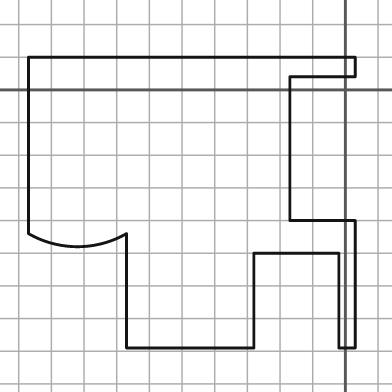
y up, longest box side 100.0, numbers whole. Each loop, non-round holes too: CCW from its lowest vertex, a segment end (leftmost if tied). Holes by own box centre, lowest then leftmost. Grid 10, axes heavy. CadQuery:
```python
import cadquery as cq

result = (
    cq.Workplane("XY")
    .moveTo(-67.0, -79.0)
    .lineTo(-28.0, -79.0)
    .lineTo(-28.0, -50.0)
    .lineTo(-2.0, -50.0)
    .lineTo(-2.0, -79.0)
    .lineTo(3.0, -79.0)
    .lineTo(3.0, -40.0)
    .lineTo(-17.0, -40.0)
    .lineTo(-17.0, 4.0)
    .lineTo(3.0, 4.0)
    .lineTo(3.0, 10.0)
    .lineTo(-97.0, 10.0)
    .lineTo(-97.0, -44.0)
    .threePointArc((-82.0, -48.0), (-67.0, -44.0))
    .close()
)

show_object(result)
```